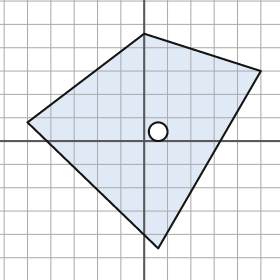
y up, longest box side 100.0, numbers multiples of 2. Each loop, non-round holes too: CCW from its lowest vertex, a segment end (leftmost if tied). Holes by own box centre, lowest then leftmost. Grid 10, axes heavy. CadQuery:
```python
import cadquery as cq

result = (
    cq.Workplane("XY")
    .moveTo(6.0, -46.0)
    .lineTo(50.0, 30.0)
    .lineTo(0.0, 46.0)
    .lineTo(-50.0, 8.0)
    .close()
    .moveTo(6.0, 4.0)
    .circle(4.0)
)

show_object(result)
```